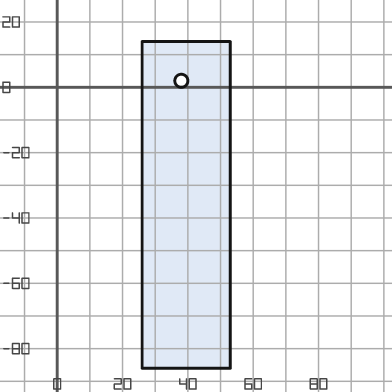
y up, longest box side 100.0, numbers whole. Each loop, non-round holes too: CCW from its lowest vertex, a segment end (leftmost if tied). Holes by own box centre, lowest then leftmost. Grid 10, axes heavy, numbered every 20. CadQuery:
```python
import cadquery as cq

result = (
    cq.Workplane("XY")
    .moveTo(26.0, -86.0)
    .lineTo(53.0, -86.0)
    .lineTo(53.0, 14.0)
    .lineTo(26.0, 14.0)
    .close()
    .moveTo(38.0, 2.0)
    .circle(2.0)
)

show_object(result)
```